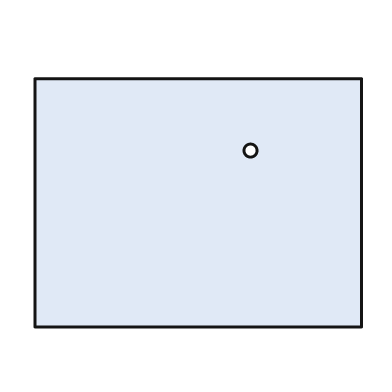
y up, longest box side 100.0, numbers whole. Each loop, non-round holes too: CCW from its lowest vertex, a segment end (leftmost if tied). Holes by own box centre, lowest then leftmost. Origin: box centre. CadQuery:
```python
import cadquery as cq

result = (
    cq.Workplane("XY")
    .moveTo(-50.0, -38.0)
    .lineTo(50.0, -38.0)
    .lineTo(50.0, 38.0)
    .lineTo(-50.0, 38.0)
    .close()
    .moveTo(16.0, 16.0)
    .circle(2.0)
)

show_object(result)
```